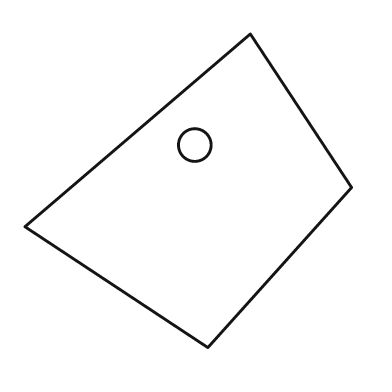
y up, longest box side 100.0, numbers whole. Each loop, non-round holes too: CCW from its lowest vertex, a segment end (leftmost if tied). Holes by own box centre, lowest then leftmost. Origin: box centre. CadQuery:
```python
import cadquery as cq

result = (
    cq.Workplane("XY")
    .moveTo(6.0, -48.0)
    .lineTo(50.0, 1.0)
    .lineTo(19.0, 48.0)
    .lineTo(-50.0, -11.0)
    .close()
    .moveTo(2.0, 14.0)
    .circle(5.0)
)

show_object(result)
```